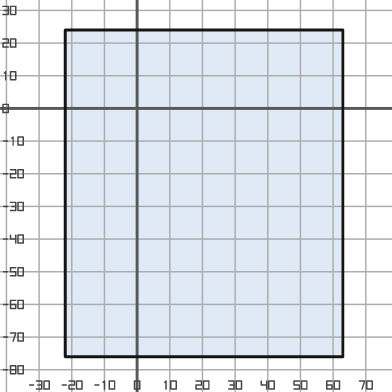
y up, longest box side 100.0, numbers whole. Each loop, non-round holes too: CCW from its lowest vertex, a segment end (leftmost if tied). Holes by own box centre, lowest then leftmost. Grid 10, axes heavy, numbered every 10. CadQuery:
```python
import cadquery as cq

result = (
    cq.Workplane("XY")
    .moveTo(-22.0, -76.0)
    .lineTo(63.0, -76.0)
    .lineTo(63.0, 24.0)
    .lineTo(-22.0, 24.0)
    .close()
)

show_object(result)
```